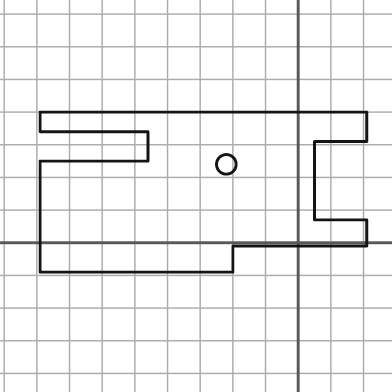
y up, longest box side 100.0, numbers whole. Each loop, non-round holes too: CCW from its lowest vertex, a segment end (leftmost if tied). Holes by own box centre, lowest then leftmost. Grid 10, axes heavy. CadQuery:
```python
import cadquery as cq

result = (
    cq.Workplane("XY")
    .moveTo(-79.0, -9.0)
    .lineTo(-20.0, -9.0)
    .lineTo(-20.0, -1.0)
    .lineTo(21.0, -1.0)
    .lineTo(21.0, 7.0)
    .lineTo(5.0, 7.0)
    .lineTo(5.0, 31.0)
    .lineTo(21.0, 31.0)
    .lineTo(21.0, 40.0)
    .lineTo(-79.0, 40.0)
    .lineTo(-79.0, 34.0)
    .lineTo(-46.0, 34.0)
    .lineTo(-46.0, 25.0)
    .lineTo(-79.0, 25.0)
    .close()
    .moveTo(-22.0, 24.0)
    .circle(3.0)
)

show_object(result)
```